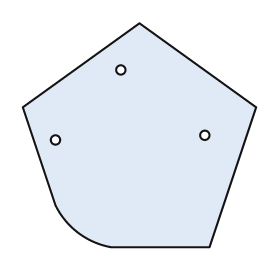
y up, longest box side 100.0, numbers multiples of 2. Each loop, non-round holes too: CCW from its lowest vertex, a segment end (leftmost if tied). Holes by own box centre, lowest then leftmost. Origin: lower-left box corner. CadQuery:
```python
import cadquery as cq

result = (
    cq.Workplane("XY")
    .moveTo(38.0, 0.0)
    .lineTo(80.0, 0.0)
    .lineTo(100.0, 60.0)
    .lineTo(50.0, 96.0)
    .lineTo(0.0, 60.0)
    .lineTo(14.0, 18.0)
    .threePointArc((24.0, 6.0), (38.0, 0.0))
    .close()
    .moveTo(14.0, 46.0)
    .circle(2.0)
    .moveTo(78.0, 48.0)
    .circle(2.0)
    .moveTo(42.0, 76.0)
    .circle(2.0)
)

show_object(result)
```